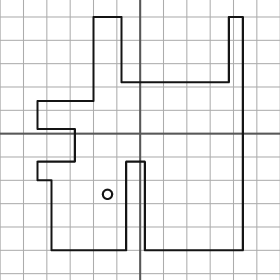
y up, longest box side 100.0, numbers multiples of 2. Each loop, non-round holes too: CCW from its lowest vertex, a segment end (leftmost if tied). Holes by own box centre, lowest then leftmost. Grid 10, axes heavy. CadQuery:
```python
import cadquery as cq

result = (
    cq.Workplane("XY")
    .moveTo(-38.0, -50.0)
    .lineTo(-6.0, -50.0)
    .lineTo(-6.0, -12.0)
    .lineTo(2.0, -12.0)
    .lineTo(2.0, -50.0)
    .lineTo(44.0, -50.0)
    .lineTo(44.0, 50.0)
    .lineTo(38.0, 50.0)
    .lineTo(38.0, 22.0)
    .lineTo(-8.0, 22.0)
    .lineTo(-8.0, 50.0)
    .lineTo(-20.0, 50.0)
    .lineTo(-20.0, 14.0)
    .lineTo(-44.0, 14.0)
    .lineTo(-44.0, 2.0)
    .lineTo(-28.0, 2.0)
    .lineTo(-28.0, -12.0)
    .lineTo(-44.0, -12.0)
    .lineTo(-44.0, -20.0)
    .lineTo(-38.0, -20.0)
    .close()
    .moveTo(-14.0, -26.0)
    .circle(2.0)
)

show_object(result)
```